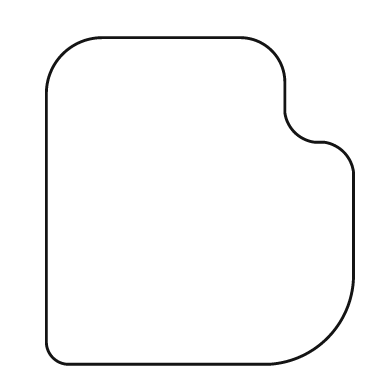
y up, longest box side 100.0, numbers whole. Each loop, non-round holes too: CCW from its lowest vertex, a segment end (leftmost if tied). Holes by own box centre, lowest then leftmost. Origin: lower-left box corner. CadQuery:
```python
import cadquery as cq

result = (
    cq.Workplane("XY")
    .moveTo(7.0, 0.0)
    .lineTo(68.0, 0.0)
    .threePointArc((86.0, 8.0), (94.0, 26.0))
    .lineTo(94.0, 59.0)
    .threePointArc((91.0, 65.0), (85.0, 68.0))
    .lineTo(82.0, 68.0)
    .threePointArc((76.0, 71.0), (73.0, 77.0))
    .lineTo(73.0, 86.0)
    .threePointArc((69.0, 96.0), (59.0, 100.0))
    .lineTo(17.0, 100.0)
    .threePointArc((5.0, 95.0), (0.0, 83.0))
    .lineTo(0.0, 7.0)
    .threePointArc((2.0, 2.0), (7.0, 0.0))
    .close()
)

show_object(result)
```